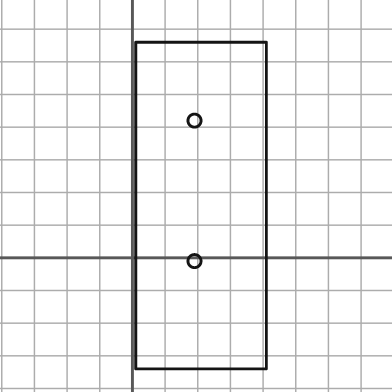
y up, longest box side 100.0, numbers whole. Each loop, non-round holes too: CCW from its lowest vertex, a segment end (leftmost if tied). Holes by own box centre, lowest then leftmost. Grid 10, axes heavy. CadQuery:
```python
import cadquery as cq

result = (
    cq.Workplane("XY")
    .moveTo(1.0, -34.0)
    .lineTo(41.0, -34.0)
    .lineTo(41.0, 66.0)
    .lineTo(1.0, 66.0)
    .close()
    .moveTo(19.0, -1.0)
    .circle(2.0)
    .moveTo(19.0, 42.0)
    .circle(2.0)
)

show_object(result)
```